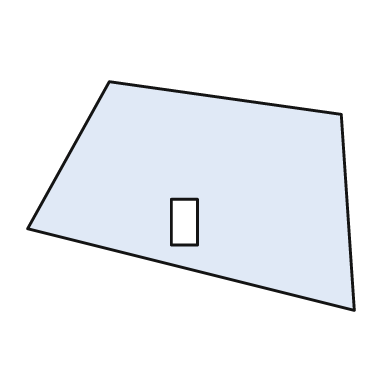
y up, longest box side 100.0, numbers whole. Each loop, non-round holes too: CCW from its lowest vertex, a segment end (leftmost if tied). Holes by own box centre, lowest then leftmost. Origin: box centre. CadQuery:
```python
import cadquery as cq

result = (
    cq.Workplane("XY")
    .moveTo(50.0, -35.0)
    .lineTo(46.0, 25.0)
    .lineTo(-25.0, 35.0)
    .lineTo(-50.0, -10.0)
    .close()
    .moveTo(-6.0, -15.0)
    .lineTo(2.0, -15.0)
    .lineTo(2.0, -1.0)
    .lineTo(-6.0, -1.0)
    .close()
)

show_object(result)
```